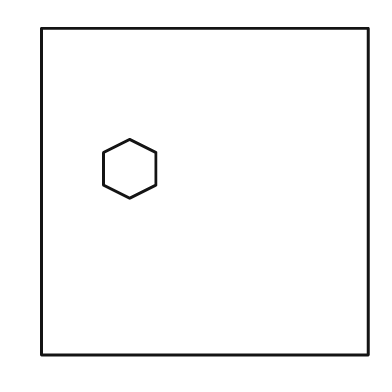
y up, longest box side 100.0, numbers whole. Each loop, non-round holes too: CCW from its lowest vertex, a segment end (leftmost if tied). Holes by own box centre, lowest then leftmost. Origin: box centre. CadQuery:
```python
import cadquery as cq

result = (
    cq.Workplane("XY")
    .moveTo(-50.0, -50.0)
    .lineTo(50.0, -50.0)
    .lineTo(50.0, 50.0)
    .lineTo(-50.0, 50.0)
    .close()
    .moveTo(-23.0, -2.0)
    .lineTo(-15.0, 2.0)
    .lineTo(-15.0, 12.0)
    .lineTo(-23.0, 16.0)
    .lineTo(-31.0, 12.0)
    .lineTo(-31.0, 2.0)
    .close()
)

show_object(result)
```